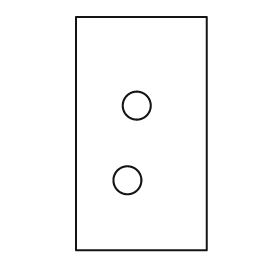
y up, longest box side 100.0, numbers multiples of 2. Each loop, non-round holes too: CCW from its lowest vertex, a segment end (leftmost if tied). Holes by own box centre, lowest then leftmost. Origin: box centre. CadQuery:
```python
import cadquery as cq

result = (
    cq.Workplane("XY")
    .moveTo(-28.0, -50.0)
    .lineTo(28.0, -50.0)
    .lineTo(28.0, 50.0)
    .lineTo(-28.0, 50.0)
    .close()
    .moveTo(-6.0, -20.0)
    .circle(6.0)
    .moveTo(-2.0, 12.0)
    .circle(6.0)
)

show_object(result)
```